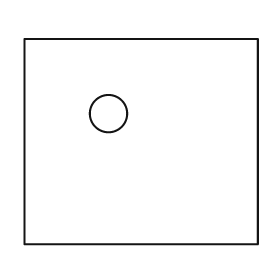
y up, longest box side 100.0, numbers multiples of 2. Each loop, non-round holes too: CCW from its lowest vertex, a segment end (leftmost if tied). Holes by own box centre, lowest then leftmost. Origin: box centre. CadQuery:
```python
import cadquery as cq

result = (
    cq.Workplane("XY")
    .moveTo(-50.0, -44.0)
    .lineTo(50.0, -44.0)
    .lineTo(50.0, 44.0)
    .lineTo(-50.0, 44.0)
    .close()
    .moveTo(-14.0, 12.0)
    .circle(8.0)
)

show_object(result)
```